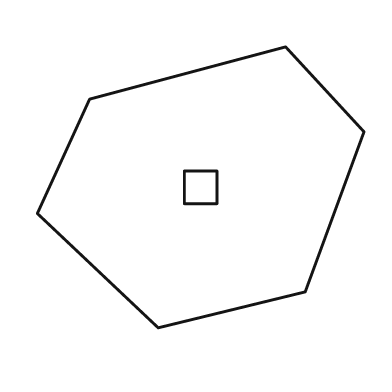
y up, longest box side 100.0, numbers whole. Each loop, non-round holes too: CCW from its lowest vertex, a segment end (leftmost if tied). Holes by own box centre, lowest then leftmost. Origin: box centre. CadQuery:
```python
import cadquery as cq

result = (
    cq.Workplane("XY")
    .moveTo(-13.0, -43.0)
    .lineTo(32.0, -32.0)
    .lineTo(50.0, 17.0)
    .lineTo(26.0, 43.0)
    .lineTo(-34.0, 27.0)
    .lineTo(-50.0, -8.0)
    .close()
    .moveTo(-5.0, -5.0)
    .lineTo(5.0, -5.0)
    .lineTo(5.0, 5.0)
    .lineTo(-5.0, 5.0)
    .close()
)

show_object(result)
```